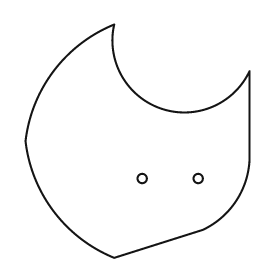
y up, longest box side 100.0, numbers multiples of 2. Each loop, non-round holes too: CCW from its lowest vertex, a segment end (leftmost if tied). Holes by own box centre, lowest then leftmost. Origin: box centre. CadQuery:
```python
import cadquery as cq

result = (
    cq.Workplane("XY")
    .moveTo(-10.0, -50.0)
    .lineTo(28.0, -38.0)
    .threePointArc((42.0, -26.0), (48.0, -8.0))
    .lineTo(48.0, 30.0)
    .threePointArc((10.0, 14.0), (-10.0, 50.0))
    .threePointArc((-36.0, 30.0), (-48.0, 0.0))
    .threePointArc((-36.0, -30.0), (-10.0, -50.0))
    .close()
    .moveTo(2.0, -16.0)
    .circle(2.0)
    .moveTo(26.0, -16.0)
    .circle(2.0)
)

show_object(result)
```